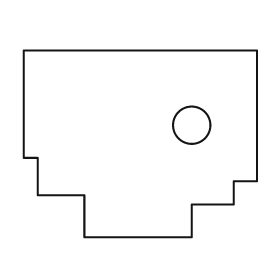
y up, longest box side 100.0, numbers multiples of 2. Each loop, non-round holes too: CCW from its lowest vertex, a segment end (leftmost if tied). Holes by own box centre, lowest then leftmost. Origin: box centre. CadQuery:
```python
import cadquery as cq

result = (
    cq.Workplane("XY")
    .moveTo(-24.0, -40.0)
    .lineTo(22.0, -40.0)
    .lineTo(22.0, -26.0)
    .lineTo(40.0, -26.0)
    .lineTo(40.0, -16.0)
    .lineTo(50.0, -16.0)
    .lineTo(50.0, 40.0)
    .lineTo(-50.0, 40.0)
    .lineTo(-50.0, -6.0)
    .lineTo(-44.0, -6.0)
    .lineTo(-44.0, -22.0)
    .lineTo(-24.0, -22.0)
    .close()
    .moveTo(22.0, 8.0)
    .circle(8.0)
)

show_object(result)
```